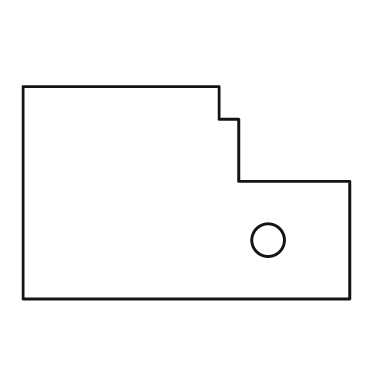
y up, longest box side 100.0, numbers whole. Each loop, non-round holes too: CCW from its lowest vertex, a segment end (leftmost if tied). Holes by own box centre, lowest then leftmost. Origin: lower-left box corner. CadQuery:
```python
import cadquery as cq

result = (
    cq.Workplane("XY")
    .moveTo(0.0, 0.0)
    .lineTo(100.0, 0.0)
    .lineTo(100.0, 36.0)
    .lineTo(66.0, 36.0)
    .lineTo(66.0, 55.0)
    .lineTo(60.0, 55.0)
    .lineTo(60.0, 65.0)
    .lineTo(0.0, 65.0)
    .close()
    .moveTo(75.0, 18.0)
    .circle(5.0)
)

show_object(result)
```